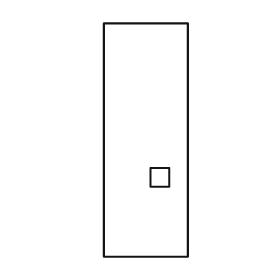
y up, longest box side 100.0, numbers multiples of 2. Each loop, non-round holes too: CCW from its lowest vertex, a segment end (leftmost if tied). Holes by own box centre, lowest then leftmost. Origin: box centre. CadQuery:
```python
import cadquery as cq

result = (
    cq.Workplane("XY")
    .moveTo(-18.0, -50.0)
    .lineTo(18.0, -50.0)
    .lineTo(18.0, 50.0)
    .lineTo(-18.0, 50.0)
    .close()
    .moveTo(2.0, -20.0)
    .lineTo(10.0, -20.0)
    .lineTo(10.0, -12.0)
    .lineTo(2.0, -12.0)
    .close()
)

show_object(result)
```